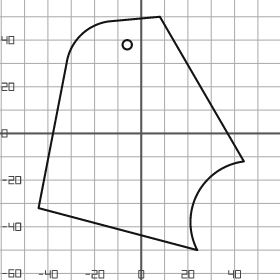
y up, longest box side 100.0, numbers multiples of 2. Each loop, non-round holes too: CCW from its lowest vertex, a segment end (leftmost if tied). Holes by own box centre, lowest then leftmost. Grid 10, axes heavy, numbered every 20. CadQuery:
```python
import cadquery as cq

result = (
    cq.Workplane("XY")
    .moveTo(24.0, -50.0)
    .threePointArc((24.0, -26.0), (44.0, -12.0))
    .lineTo(8.0, 50.0)
    .lineTo(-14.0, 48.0)
    .threePointArc((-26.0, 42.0), (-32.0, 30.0))
    .lineTo(-44.0, -32.0)
    .close()
    .moveTo(-6.0, 38.0)
    .circle(2.0)
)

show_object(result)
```